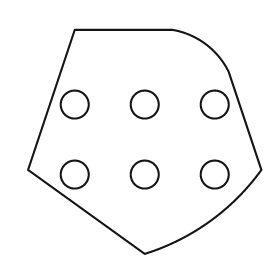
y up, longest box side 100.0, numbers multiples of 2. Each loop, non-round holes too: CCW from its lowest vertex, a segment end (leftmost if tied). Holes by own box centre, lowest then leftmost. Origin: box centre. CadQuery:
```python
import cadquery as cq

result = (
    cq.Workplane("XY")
    .moveTo(0.0, -48.0)
    .threePointArc((28.0, -34.0), (50.0, -12.0))
    .lineTo(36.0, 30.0)
    .threePointArc((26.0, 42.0), (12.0, 48.0))
    .lineTo(-30.0, 48.0)
    .lineTo(-50.0, -12.0)
    .close()
    .moveTo(-30.0, -14.0)
    .circle(6.0)
    .moveTo(0.0, -14.0)
    .circle(6.0)
    .moveTo(30.0, -14.0)
    .circle(6.0)
    .moveTo(-30.0, 16.0)
    .circle(6.0)
    .moveTo(0.0, 16.0)
    .circle(6.0)
    .moveTo(30.0, 16.0)
    .circle(6.0)
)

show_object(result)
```